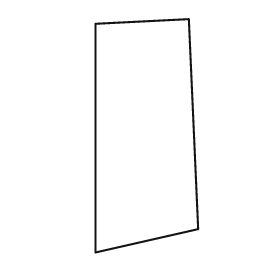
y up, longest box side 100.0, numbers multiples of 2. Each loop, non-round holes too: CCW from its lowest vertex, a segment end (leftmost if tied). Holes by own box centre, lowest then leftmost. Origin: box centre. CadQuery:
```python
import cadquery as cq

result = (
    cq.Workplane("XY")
    .moveTo(-22.0, -50.0)
    .lineTo(22.0, -40.0)
    .lineTo(18.0, 50.0)
    .lineTo(-22.0, 48.0)
    .close()
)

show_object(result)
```